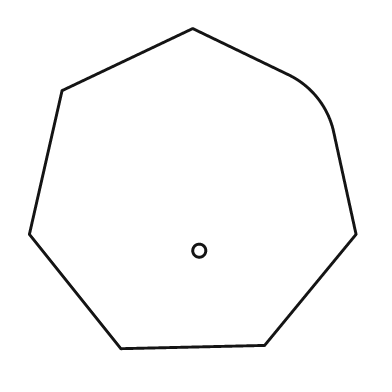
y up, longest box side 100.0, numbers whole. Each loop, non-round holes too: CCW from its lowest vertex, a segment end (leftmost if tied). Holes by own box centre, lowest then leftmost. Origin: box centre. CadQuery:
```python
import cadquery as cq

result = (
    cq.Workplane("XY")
    .moveTo(-22.0, -49.0)
    .lineTo(22.0, -48.0)
    .lineTo(50.0, -14.0)
    .lineTo(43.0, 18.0)
    .threePointArc((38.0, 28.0), (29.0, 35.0))
    .lineTo(0.0, 49.0)
    .lineTo(-40.0, 30.0)
    .lineTo(-50.0, -14.0)
    .close()
    .moveTo(2.0, -19.0)
    .circle(2.0)
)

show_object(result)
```